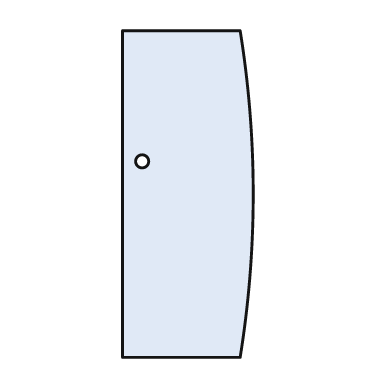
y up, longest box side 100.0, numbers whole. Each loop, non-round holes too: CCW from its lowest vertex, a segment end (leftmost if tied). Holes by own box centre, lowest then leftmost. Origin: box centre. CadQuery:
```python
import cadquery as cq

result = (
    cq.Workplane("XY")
    .moveTo(-20.0, -50.0)
    .lineTo(16.0, -50.0)
    .threePointArc((20.0, 0.0), (16.0, 50.0))
    .lineTo(-20.0, 50.0)
    .close()
    .moveTo(-14.0, 10.0)
    .circle(2.0)
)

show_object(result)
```